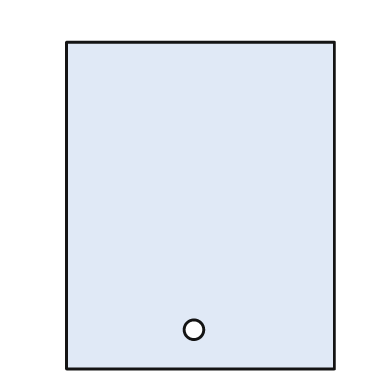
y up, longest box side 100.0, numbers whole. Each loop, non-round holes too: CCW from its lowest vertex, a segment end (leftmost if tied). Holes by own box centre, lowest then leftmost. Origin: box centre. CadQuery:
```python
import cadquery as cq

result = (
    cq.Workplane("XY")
    .moveTo(-41.0, -50.0)
    .lineTo(41.0, -50.0)
    .lineTo(41.0, 50.0)
    .lineTo(-41.0, 50.0)
    .close()
    .moveTo(-2.0, -38.0)
    .circle(3.0)
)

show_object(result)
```